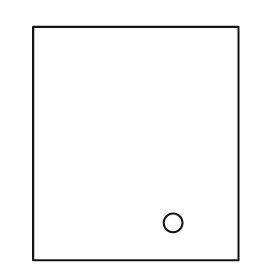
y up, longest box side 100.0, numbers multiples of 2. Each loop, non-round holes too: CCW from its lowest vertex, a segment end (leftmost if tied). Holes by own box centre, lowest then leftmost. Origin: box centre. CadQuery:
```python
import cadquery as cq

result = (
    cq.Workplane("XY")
    .moveTo(-44.0, -50.0)
    .lineTo(44.0, -50.0)
    .lineTo(44.0, 50.0)
    .lineTo(-44.0, 50.0)
    .close()
    .moveTo(16.0, -34.0)
    .circle(4.0)
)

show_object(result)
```